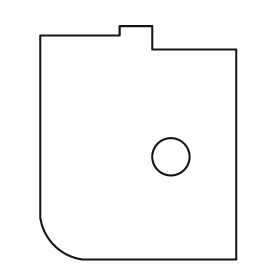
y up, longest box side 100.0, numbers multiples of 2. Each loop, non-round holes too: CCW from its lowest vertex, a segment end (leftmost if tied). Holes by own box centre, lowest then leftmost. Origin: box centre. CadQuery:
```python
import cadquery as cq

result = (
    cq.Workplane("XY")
    .moveTo(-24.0, -50.0)
    .lineTo(42.0, -50.0)
    .lineTo(42.0, 40.0)
    .lineTo(6.0, 40.0)
    .lineTo(6.0, 50.0)
    .lineTo(-8.0, 50.0)
    .lineTo(-8.0, 46.0)
    .lineTo(-42.0, 46.0)
    .lineTo(-42.0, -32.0)
    .threePointArc((-36.0, -44.0), (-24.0, -50.0))
    .close()
    .moveTo(14.0, -6.0)
    .circle(8.0)
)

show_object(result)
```